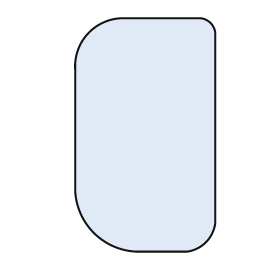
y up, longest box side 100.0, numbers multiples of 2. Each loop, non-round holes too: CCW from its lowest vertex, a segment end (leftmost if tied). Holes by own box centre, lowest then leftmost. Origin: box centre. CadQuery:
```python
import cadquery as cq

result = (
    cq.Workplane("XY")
    .moveTo(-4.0, -50.0)
    .lineTo(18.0, -50.0)
    .threePointArc((26.0, -46.0), (30.0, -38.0))
    .lineTo(30.0, 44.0)
    .threePointArc((28.0, 48.0), (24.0, 50.0))
    .lineTo(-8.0, 50.0)
    .threePointArc((-24.0, 44.0), (-30.0, 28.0))
    .lineTo(-30.0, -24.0)
    .threePointArc((-22.0, -42.0), (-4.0, -50.0))
    .close()
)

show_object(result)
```